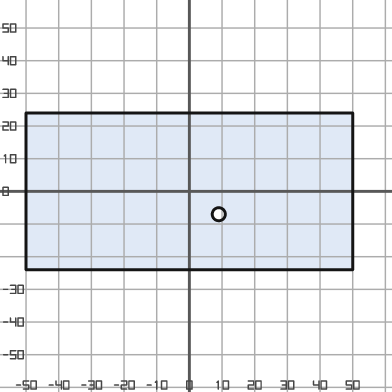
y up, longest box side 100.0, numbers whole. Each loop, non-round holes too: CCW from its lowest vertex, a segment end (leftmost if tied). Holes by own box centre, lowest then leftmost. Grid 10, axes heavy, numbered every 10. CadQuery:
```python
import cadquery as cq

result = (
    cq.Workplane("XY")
    .moveTo(-50.0, -24.0)
    .lineTo(50.0, -24.0)
    .lineTo(50.0, 24.0)
    .lineTo(-50.0, 24.0)
    .close()
    .moveTo(9.0, -7.0)
    .circle(2.0)
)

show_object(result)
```